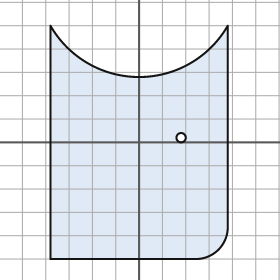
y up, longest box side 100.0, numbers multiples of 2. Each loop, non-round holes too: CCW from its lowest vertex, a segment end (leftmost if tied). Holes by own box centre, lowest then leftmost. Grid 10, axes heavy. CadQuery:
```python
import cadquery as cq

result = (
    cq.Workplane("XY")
    .moveTo(-38.0, -50.0)
    .lineTo(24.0, -50.0)
    .threePointArc((34.0, -46.0), (38.0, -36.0))
    .lineTo(38.0, 50.0)
    .threePointArc((0.0, 28.0), (-38.0, 50.0))
    .close()
    .moveTo(18.0, 2.0)
    .circle(2.0)
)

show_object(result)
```